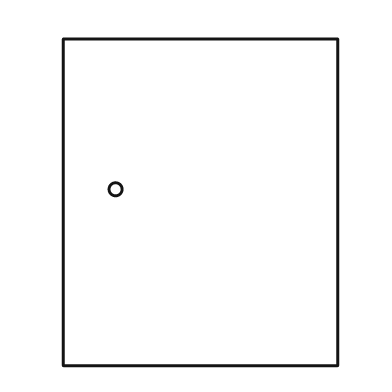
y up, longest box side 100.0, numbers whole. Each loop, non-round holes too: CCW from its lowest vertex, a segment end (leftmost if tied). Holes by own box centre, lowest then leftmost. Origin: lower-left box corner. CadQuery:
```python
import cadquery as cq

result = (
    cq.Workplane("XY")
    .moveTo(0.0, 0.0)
    .lineTo(84.0, 0.0)
    .lineTo(84.0, 100.0)
    .lineTo(0.0, 100.0)
    .close()
    .moveTo(16.0, 54.0)
    .circle(2.0)
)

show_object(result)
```